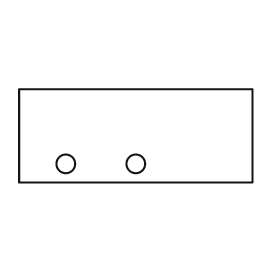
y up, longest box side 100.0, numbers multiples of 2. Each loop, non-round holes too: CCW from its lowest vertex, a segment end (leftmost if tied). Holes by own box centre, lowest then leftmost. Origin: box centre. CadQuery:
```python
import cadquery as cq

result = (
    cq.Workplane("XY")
    .moveTo(-50.0, -20.0)
    .lineTo(50.0, -20.0)
    .lineTo(50.0, 20.0)
    .lineTo(-50.0, 20.0)
    .close()
    .moveTo(-30.0, -12.0)
    .circle(4.0)
    .moveTo(0.0, -12.0)
    .circle(4.0)
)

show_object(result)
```